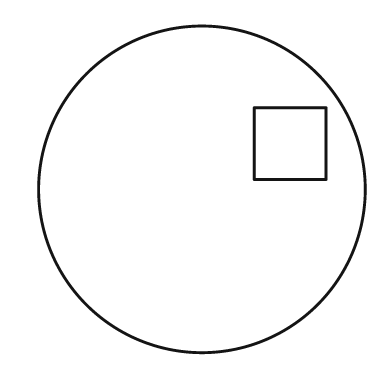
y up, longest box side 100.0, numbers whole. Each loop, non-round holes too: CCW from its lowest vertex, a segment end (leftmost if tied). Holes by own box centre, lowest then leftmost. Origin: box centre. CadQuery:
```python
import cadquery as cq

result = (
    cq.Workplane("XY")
    .moveTo(0.0, 0.0)
    .circle(50.0)
    .moveTo(16.0, 3.0)
    .lineTo(38.0, 3.0)
    .lineTo(38.0, 25.0)
    .lineTo(16.0, 25.0)
    .close()
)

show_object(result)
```